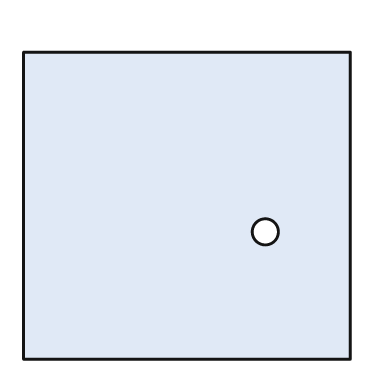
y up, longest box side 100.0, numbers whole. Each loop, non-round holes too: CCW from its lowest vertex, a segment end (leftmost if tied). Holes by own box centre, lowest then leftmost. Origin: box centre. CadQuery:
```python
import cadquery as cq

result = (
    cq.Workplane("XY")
    .moveTo(-50.0, -47.0)
    .lineTo(50.0, -47.0)
    .lineTo(50.0, 47.0)
    .lineTo(-50.0, 47.0)
    .close()
    .moveTo(24.0, -8.0)
    .circle(4.0)
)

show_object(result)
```